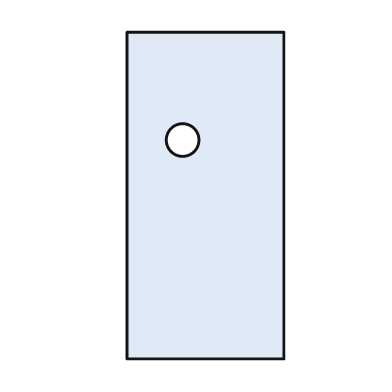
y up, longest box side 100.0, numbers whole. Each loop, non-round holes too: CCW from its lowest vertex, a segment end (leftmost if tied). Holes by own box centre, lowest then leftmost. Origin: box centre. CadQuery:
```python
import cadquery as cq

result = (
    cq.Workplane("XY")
    .moveTo(-24.0, -50.0)
    .lineTo(24.0, -50.0)
    .lineTo(24.0, 50.0)
    .lineTo(-24.0, 50.0)
    .close()
    .moveTo(-7.0, 17.0)
    .circle(5.0)
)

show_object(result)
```